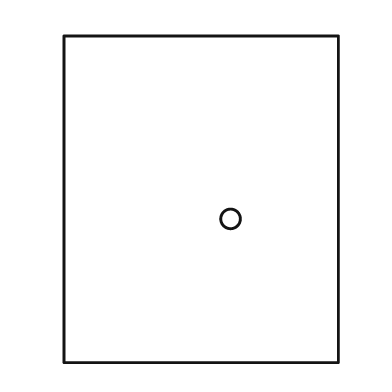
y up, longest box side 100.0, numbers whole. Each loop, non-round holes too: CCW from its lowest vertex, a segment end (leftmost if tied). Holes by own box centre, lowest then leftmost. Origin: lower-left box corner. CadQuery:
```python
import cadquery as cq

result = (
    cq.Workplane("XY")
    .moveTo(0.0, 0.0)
    .lineTo(84.0, 0.0)
    .lineTo(84.0, 100.0)
    .lineTo(0.0, 100.0)
    .close()
    .moveTo(51.0, 44.0)
    .circle(3.0)
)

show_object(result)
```